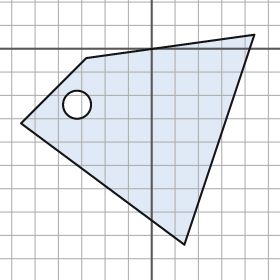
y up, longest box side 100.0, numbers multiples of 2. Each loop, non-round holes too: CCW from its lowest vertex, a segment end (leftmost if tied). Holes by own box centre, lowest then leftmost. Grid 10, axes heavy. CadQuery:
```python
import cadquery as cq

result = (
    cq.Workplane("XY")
    .moveTo(14.0, -84.0)
    .lineTo(44.0, 6.0)
    .lineTo(-28.0, -4.0)
    .lineTo(-56.0, -32.0)
    .close()
    .moveTo(-32.0, -24.0)
    .circle(6.0)
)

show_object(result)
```